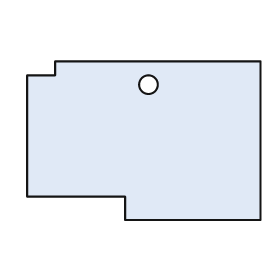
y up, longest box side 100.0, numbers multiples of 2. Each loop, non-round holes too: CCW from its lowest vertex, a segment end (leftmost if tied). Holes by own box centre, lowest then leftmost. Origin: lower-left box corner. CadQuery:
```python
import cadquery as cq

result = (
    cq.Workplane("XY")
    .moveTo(42.0, 0.0)
    .lineTo(100.0, 0.0)
    .lineTo(100.0, 68.0)
    .lineTo(12.0, 68.0)
    .lineTo(12.0, 62.0)
    .lineTo(0.0, 62.0)
    .lineTo(0.0, 10.0)
    .lineTo(42.0, 10.0)
    .close()
    .moveTo(52.0, 58.0)
    .circle(4.0)
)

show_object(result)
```